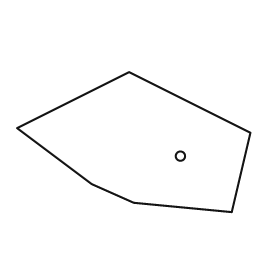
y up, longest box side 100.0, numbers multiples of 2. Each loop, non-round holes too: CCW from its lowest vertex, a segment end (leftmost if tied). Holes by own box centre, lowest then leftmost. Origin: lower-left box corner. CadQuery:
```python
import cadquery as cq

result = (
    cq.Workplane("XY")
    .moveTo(92.0, 0.0)
    .lineTo(100.0, 34.0)
    .lineTo(48.0, 60.0)
    .lineTo(0.0, 36.0)
    .lineTo(32.0, 12.0)
    .lineTo(50.0, 4.0)
    .close()
    .moveTo(70.0, 24.0)
    .circle(2.0)
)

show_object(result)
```